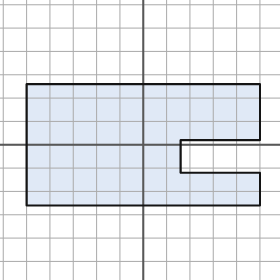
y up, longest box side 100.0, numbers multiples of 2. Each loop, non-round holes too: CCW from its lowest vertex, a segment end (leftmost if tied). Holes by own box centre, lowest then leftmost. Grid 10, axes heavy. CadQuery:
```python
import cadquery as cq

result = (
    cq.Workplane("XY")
    .moveTo(-50.0, -26.0)
    .lineTo(50.0, -26.0)
    .lineTo(50.0, -12.0)
    .lineTo(16.0, -12.0)
    .lineTo(16.0, 2.0)
    .lineTo(50.0, 2.0)
    .lineTo(50.0, 26.0)
    .lineTo(-50.0, 26.0)
    .close()
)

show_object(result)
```